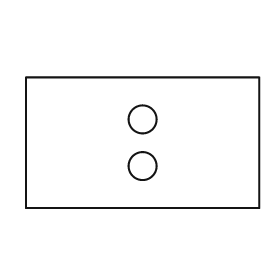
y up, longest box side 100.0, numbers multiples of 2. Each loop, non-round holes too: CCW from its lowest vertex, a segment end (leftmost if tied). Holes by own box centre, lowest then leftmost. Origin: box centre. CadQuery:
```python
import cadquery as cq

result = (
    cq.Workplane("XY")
    .moveTo(-50.0, -28.0)
    .lineTo(50.0, -28.0)
    .lineTo(50.0, 28.0)
    .lineTo(-50.0, 28.0)
    .close()
    .moveTo(0.0, -10.0)
    .circle(6.0)
    .moveTo(0.0, 10.0)
    .circle(6.0)
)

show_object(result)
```